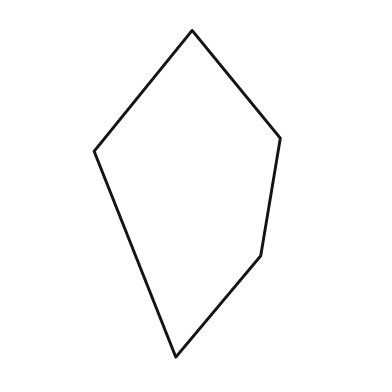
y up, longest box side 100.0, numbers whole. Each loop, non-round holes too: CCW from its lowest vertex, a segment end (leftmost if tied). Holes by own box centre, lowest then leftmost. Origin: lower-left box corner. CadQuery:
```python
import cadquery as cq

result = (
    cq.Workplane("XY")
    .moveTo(25.0, 0.0)
    .lineTo(51.0, 31.0)
    .lineTo(57.0, 67.0)
    .lineTo(30.0, 100.0)
    .lineTo(0.0, 63.0)
    .close()
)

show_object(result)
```